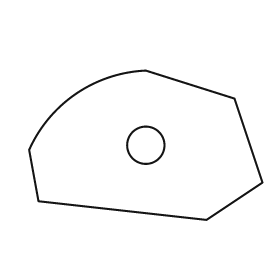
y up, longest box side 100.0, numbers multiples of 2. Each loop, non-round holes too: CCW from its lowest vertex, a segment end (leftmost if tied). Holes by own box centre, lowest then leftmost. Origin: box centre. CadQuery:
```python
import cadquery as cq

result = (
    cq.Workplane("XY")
    .moveTo(26.0, -32.0)
    .lineTo(50.0, -16.0)
    .lineTo(38.0, 20.0)
    .lineTo(0.0, 32.0)
    .threePointArc((-30.0, 22.0), (-50.0, -2.0))
    .lineTo(-46.0, -24.0)
    .close()
    .moveTo(0.0, 0.0)
    .circle(8.0)
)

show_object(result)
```